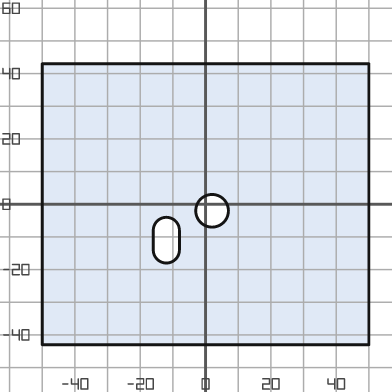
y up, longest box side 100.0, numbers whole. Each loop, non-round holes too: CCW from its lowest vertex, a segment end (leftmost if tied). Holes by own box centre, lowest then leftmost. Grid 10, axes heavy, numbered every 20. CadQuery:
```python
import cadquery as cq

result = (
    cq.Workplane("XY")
    .moveTo(-50.0, -43.0)
    .lineTo(50.0, -43.0)
    .lineTo(50.0, 43.0)
    .lineTo(-50.0, 43.0)
    .close()
    .moveTo(-16.0, -14.0)
    .threePointArc((-12.0, -18.0), (-8.0, -14.0))
    .lineTo(-8.0, -8.0)
    .threePointArc((-12.0, -4.0), (-16.0, -8.0))
    .close()
    .moveTo(2.0, -2.0)
    .circle(5.0)
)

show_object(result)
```